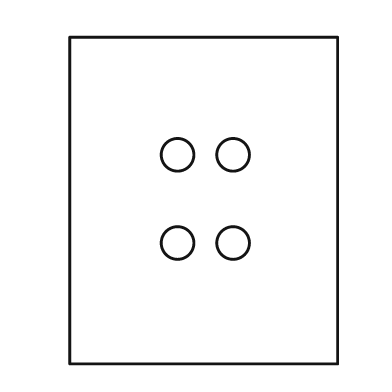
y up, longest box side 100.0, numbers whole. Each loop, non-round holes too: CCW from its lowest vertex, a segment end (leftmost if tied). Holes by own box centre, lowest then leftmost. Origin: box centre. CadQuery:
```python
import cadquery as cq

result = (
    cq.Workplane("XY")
    .moveTo(-41.0, -50.0)
    .lineTo(41.0, -50.0)
    .lineTo(41.0, 50.0)
    .lineTo(-41.0, 50.0)
    .close()
    .moveTo(-8.0, -13.0)
    .circle(5.0)
    .moveTo(9.0, -13.0)
    .circle(5.0)
    .moveTo(-8.0, 14.0)
    .circle(5.0)
    .moveTo(9.0, 14.0)
    .circle(5.0)
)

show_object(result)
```